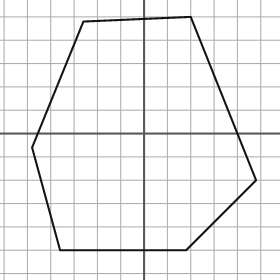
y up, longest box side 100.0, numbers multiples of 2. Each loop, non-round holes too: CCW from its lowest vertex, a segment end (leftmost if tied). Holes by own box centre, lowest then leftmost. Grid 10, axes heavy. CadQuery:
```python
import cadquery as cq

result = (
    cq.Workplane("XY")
    .moveTo(-36.0, -50.0)
    .lineTo(18.0, -50.0)
    .lineTo(48.0, -20.0)
    .lineTo(20.0, 50.0)
    .lineTo(-26.0, 48.0)
    .lineTo(-48.0, -6.0)
    .close()
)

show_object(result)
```